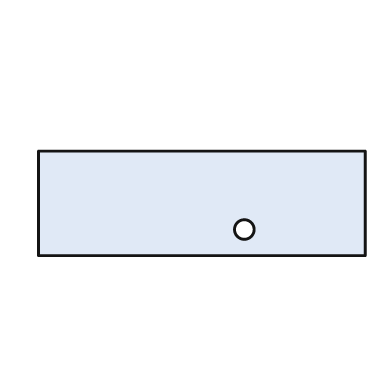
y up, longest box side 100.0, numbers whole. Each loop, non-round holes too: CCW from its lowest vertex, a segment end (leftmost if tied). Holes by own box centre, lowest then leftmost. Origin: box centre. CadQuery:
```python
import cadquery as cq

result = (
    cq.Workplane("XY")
    .moveTo(-50.0, -16.0)
    .lineTo(50.0, -16.0)
    .lineTo(50.0, 16.0)
    .lineTo(-50.0, 16.0)
    .close()
    .moveTo(13.0, -8.0)
    .circle(3.0)
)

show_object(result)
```